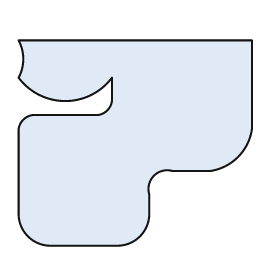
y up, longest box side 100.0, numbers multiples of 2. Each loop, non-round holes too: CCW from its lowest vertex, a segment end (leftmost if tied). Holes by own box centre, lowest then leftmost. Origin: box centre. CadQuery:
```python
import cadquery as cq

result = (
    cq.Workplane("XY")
    .moveTo(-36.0, -44.0)
    .lineTo(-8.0, -44.0)
    .threePointArc((2.0, -40.0), (6.0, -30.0))
    .lineTo(6.0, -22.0)
    .threePointArc((8.0, -14.0), (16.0, -12.0))
    .lineTo(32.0, -12.0)
    .threePointArc((44.0, -6.0), (50.0, 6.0))
    .lineTo(50.0, 44.0)
    .lineTo(-50.0, 44.0)
    .threePointArc((-48.0, 36.0), (-50.0, 28.0))
    .threePointArc((-30.0, 18.0), (-10.0, 28.0))
    .lineTo(-10.0, 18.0)
    .threePointArc((-12.0, 14.0), (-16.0, 12.0))
    .lineTo(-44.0, 12.0)
    .threePointArc((-48.0, 10.0), (-50.0, 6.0))
    .lineTo(-50.0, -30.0)
    .threePointArc((-46.0, -40.0), (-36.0, -44.0))
    .close()
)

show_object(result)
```